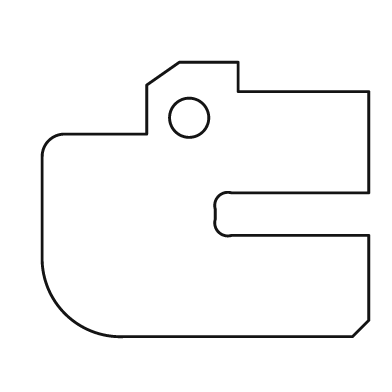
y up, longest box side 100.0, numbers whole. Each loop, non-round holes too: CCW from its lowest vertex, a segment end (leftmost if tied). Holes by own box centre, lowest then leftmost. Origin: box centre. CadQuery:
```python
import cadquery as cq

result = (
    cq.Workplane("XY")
    .moveTo(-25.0, -42.0)
    .lineTo(45.0, -42.0)
    .lineTo(50.0, -37.0)
    .lineTo(50.0, -11.0)
    .lineTo(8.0, -11.0)
    .threePointArc((4.0, -10.0), (3.0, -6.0))
    .lineTo(3.0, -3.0)
    .threePointArc((4.0, 1.0), (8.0, 2.0))
    .lineTo(50.0, 2.0)
    .lineTo(50.0, 33.0)
    .lineTo(10.0, 33.0)
    .lineTo(10.0, 42.0)
    .lineTo(-8.0, 42.0)
    .lineTo(-18.0, 35.0)
    .lineTo(-18.0, 20.0)
    .lineTo(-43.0, 20.0)
    .threePointArc((-48.0, 18.0), (-50.0, 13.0))
    .lineTo(-50.0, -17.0)
    .threePointArc((-43.0, -35.0), (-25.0, -42.0))
    .close()
    .moveTo(-5.0, 25.0)
    .circle(6.0)
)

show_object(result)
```